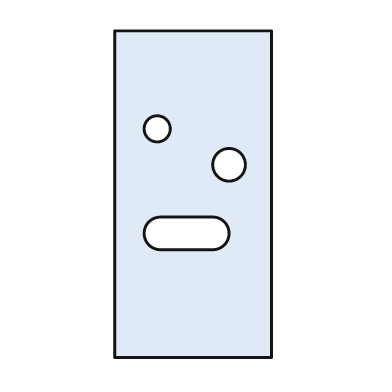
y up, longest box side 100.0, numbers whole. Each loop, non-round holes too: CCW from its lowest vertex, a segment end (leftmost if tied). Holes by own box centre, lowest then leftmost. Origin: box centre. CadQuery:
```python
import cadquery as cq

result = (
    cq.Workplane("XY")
    .moveTo(-24.0, -50.0)
    .lineTo(24.0, -50.0)
    .lineTo(24.0, 50.0)
    .lineTo(-24.0, 50.0)
    .close()
    .moveTo(-10.0, -17.0)
    .lineTo(6.0, -17.0)
    .threePointArc((11.0, -12.0), (6.0, -7.0))
    .lineTo(-10.0, -7.0)
    .threePointArc((-15.0, -12.0), (-10.0, -17.0))
    .close()
    .moveTo(11.0, 9.0)
    .circle(5.0)
    .moveTo(-11.0, 20.0)
    .circle(4.0)
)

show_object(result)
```